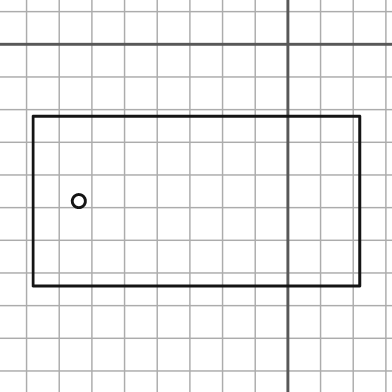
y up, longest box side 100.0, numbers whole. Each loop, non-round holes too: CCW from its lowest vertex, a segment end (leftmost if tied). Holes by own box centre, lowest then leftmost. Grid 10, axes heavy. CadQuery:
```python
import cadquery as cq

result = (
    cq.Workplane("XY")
    .moveTo(-78.0, -74.0)
    .lineTo(22.0, -74.0)
    .lineTo(22.0, -22.0)
    .lineTo(-78.0, -22.0)
    .close()
    .moveTo(-64.0, -48.0)
    .circle(2.0)
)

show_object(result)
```